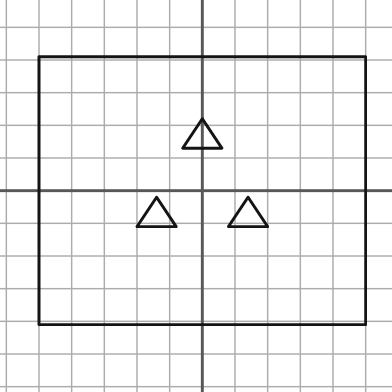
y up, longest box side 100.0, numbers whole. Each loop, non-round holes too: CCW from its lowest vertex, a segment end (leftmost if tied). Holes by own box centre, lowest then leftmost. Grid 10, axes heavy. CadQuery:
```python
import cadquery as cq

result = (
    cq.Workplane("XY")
    .moveTo(-50.0, -41.0)
    .lineTo(50.0, -41.0)
    .lineTo(50.0, 41.0)
    .lineTo(-50.0, 41.0)
    .close()
    .moveTo(-20.0, -11.0)
    .lineTo(-8.0, -11.0)
    .lineTo(-14.0, -2.0)
    .close()
    .moveTo(8.0, -11.0)
    .lineTo(20.0, -11.0)
    .lineTo(14.0, -2.0)
    .close()
    .moveTo(-6.0, 13.0)
    .lineTo(6.0, 13.0)
    .lineTo(0.0, 22.0)
    .close()
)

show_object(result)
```